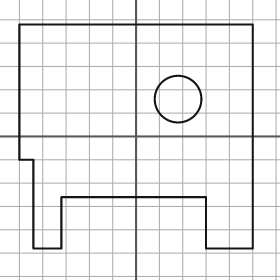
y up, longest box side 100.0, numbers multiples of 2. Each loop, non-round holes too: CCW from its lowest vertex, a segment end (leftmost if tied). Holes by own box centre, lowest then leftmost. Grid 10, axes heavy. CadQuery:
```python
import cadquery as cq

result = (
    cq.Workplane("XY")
    .moveTo(-44.0, -48.0)
    .lineTo(-32.0, -48.0)
    .lineTo(-32.0, -26.0)
    .lineTo(30.0, -26.0)
    .lineTo(30.0, -48.0)
    .lineTo(50.0, -48.0)
    .lineTo(50.0, 48.0)
    .lineTo(-50.0, 48.0)
    .lineTo(-50.0, -10.0)
    .lineTo(-44.0, -10.0)
    .close()
    .moveTo(18.0, 16.0)
    .circle(10.0)
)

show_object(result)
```